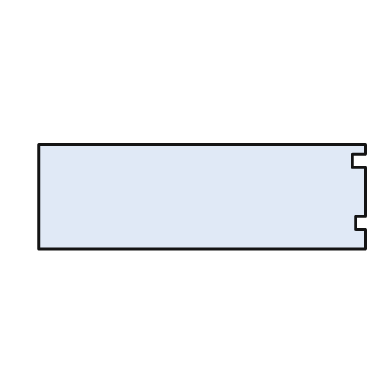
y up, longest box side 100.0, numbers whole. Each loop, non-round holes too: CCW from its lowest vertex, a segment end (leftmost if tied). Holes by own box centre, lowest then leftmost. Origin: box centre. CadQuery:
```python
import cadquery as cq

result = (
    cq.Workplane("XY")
    .moveTo(-50.0, -16.0)
    .lineTo(50.0, -16.0)
    .lineTo(50.0, -10.0)
    .lineTo(47.0, -10.0)
    .lineTo(47.0, -6.0)
    .lineTo(50.0, -6.0)
    .lineTo(50.0, 9.0)
    .lineTo(46.0, 9.0)
    .lineTo(46.0, 13.0)
    .lineTo(50.0, 13.0)
    .lineTo(50.0, 16.0)
    .lineTo(-50.0, 16.0)
    .close()
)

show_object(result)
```